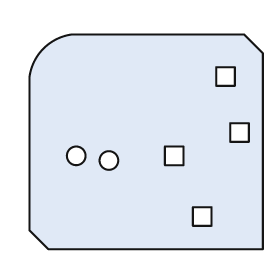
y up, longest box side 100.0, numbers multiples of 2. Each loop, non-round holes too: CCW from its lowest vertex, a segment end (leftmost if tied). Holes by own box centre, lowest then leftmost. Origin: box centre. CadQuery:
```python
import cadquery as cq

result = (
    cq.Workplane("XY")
    .moveTo(-42.0, -46.0)
    .lineTo(50.0, -46.0)
    .lineTo(50.0, 38.0)
    .lineTo(42.0, 46.0)
    .lineTo(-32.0, 46.0)
    .threePointArc((-44.0, 40.0), (-50.0, 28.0))
    .lineTo(-50.0, -38.0)
    .close()
    .moveTo(20.0, -36.0)
    .lineTo(28.0, -36.0)
    .lineTo(28.0, -28.0)
    .lineTo(20.0, -28.0)
    .close()
    .moveTo(-16.0, -8.0)
    .circle(4.0)
    .moveTo(-30.0, -6.0)
    .circle(4.0)
    .moveTo(8.0, -10.0)
    .lineTo(16.0, -10.0)
    .lineTo(16.0, -2.0)
    .lineTo(8.0, -2.0)
    .close()
    .moveTo(36.0, 0.0)
    .lineTo(44.0, 0.0)
    .lineTo(44.0, 8.0)
    .lineTo(36.0, 8.0)
    .close()
    .moveTo(30.0, 24.0)
    .lineTo(38.0, 24.0)
    .lineTo(38.0, 32.0)
    .lineTo(30.0, 32.0)
    .close()
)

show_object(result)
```